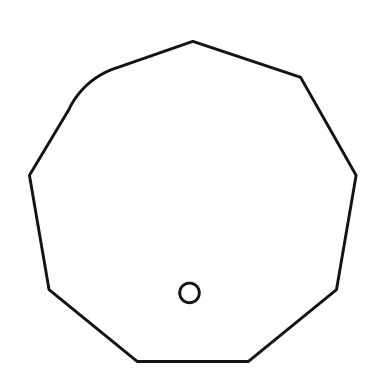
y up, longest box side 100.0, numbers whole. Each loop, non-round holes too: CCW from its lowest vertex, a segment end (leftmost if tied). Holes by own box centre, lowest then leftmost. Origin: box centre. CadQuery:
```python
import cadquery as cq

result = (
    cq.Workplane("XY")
    .moveTo(-17.0, -49.0)
    .lineTo(17.0, -49.0)
    .lineTo(44.0, -27.0)
    .lineTo(50.0, 8.0)
    .lineTo(33.0, 38.0)
    .lineTo(0.0, 49.0)
    .lineTo(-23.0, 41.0)
    .threePointArc((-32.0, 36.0), (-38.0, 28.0))
    .lineTo(-50.0, 8.0)
    .lineTo(-44.0, -27.0)
    .close()
    .moveTo(-1.0, -28.0)
    .circle(3.0)
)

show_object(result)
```